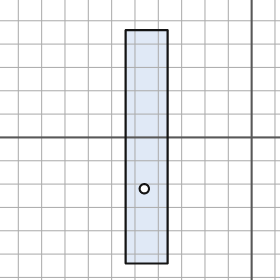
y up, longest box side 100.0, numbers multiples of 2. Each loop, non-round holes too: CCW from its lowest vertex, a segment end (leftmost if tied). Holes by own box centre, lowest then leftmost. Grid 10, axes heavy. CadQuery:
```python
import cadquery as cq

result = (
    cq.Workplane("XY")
    .moveTo(-54.0, -54.0)
    .lineTo(-36.0, -54.0)
    .lineTo(-36.0, 46.0)
    .lineTo(-54.0, 46.0)
    .close()
    .moveTo(-46.0, -22.0)
    .circle(2.0)
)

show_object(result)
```